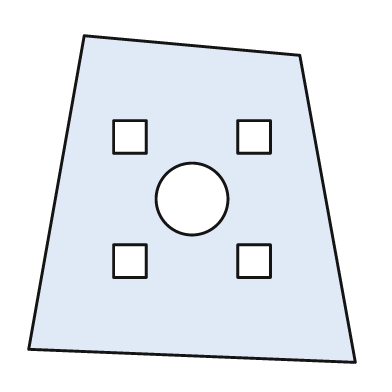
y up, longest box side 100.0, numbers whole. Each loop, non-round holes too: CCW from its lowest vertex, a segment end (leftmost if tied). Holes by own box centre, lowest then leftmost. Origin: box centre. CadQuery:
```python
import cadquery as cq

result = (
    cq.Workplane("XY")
    .moveTo(50.0, -50.0)
    .lineTo(33.0, 44.0)
    .lineTo(-33.0, 50.0)
    .lineTo(-50.0, -46.0)
    .close()
    .moveTo(-24.0, -24.0)
    .lineTo(-14.0, -24.0)
    .lineTo(-14.0, -14.0)
    .lineTo(-24.0, -14.0)
    .close()
    .moveTo(14.0, -24.0)
    .lineTo(24.0, -24.0)
    .lineTo(24.0, -14.0)
    .lineTo(14.0, -14.0)
    .close()
    .moveTo(0.0, 0.0)
    .circle(11.0)
    .moveTo(-24.0, 14.0)
    .lineTo(-14.0, 14.0)
    .lineTo(-14.0, 24.0)
    .lineTo(-24.0, 24.0)
    .close()
    .moveTo(14.0, 14.0)
    .lineTo(24.0, 14.0)
    .lineTo(24.0, 24.0)
    .lineTo(14.0, 24.0)
    .close()
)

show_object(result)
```